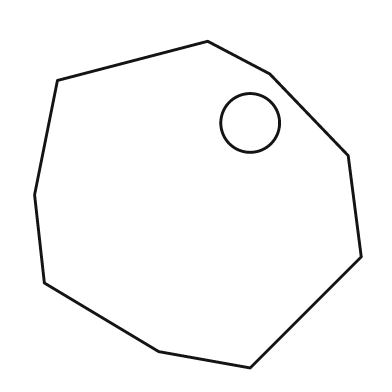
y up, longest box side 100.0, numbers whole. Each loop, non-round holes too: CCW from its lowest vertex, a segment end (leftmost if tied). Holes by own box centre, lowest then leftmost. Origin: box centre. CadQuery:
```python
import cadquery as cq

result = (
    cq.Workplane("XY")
    .moveTo(16.0, -50.0)
    .lineTo(50.0, -16.0)
    .lineTo(46.0, 15.0)
    .lineTo(22.0, 40.0)
    .lineTo(3.0, 50.0)
    .lineTo(-43.0, 38.0)
    .lineTo(-50.0, 3.0)
    .lineTo(-47.0, -24.0)
    .lineTo(-12.0, -45.0)
    .close()
    .moveTo(16.0, 25.0)
    .circle(9.0)
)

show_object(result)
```